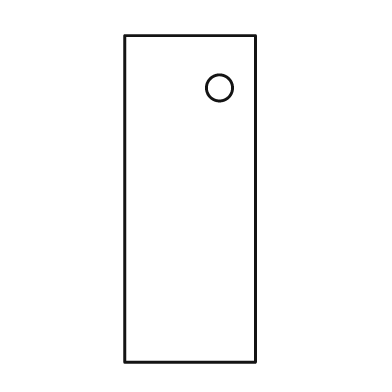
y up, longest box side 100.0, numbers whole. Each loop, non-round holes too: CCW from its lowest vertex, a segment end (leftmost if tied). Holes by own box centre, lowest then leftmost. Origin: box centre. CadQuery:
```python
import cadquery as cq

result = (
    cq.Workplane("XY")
    .moveTo(-20.0, -50.0)
    .lineTo(20.0, -50.0)
    .lineTo(20.0, 50.0)
    .lineTo(-20.0, 50.0)
    .close()
    .moveTo(9.0, 34.0)
    .circle(4.0)
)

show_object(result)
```